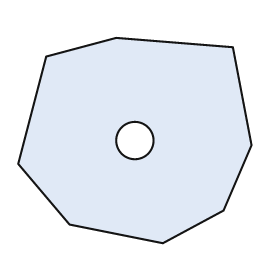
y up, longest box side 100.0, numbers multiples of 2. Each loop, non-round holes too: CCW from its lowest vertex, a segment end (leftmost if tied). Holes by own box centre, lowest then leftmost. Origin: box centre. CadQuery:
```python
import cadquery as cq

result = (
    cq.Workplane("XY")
    .moveTo(12.0, -44.0)
    .lineTo(38.0, -30.0)
    .lineTo(50.0, -2.0)
    .lineTo(42.0, 40.0)
    .lineTo(-8.0, 44.0)
    .lineTo(-38.0, 36.0)
    .lineTo(-50.0, -10.0)
    .lineTo(-28.0, -36.0)
    .close()
    .moveTo(0.0, 0.0)
    .circle(8.0)
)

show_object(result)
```